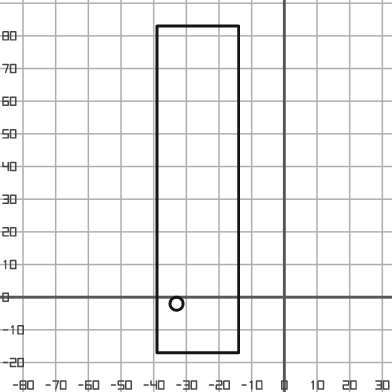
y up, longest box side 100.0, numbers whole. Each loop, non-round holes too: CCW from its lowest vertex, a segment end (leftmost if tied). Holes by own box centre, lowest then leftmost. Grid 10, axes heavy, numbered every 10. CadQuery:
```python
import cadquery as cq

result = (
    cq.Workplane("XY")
    .moveTo(-39.0, -17.0)
    .lineTo(-14.0, -17.0)
    .lineTo(-14.0, 83.0)
    .lineTo(-39.0, 83.0)
    .close()
    .moveTo(-33.0, -2.0)
    .circle(2.0)
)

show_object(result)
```